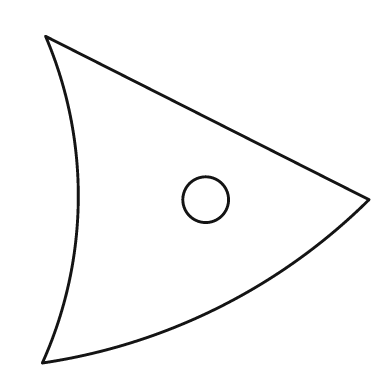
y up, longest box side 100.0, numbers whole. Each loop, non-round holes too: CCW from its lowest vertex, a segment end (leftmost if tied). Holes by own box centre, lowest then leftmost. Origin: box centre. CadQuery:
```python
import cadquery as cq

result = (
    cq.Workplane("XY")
    .moveTo(-50.0, -50.0)
    .threePointArc((4.0, -33.0), (50.0, 0.0))
    .lineTo(-49.0, 50.0)
    .threePointArc((-39.0, 0.0), (-50.0, -50.0))
    .close()
    .moveTo(0.0, 0.0)
    .circle(7.0)
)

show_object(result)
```